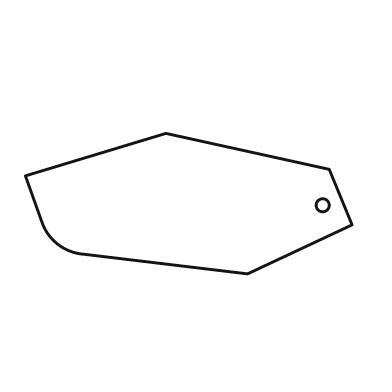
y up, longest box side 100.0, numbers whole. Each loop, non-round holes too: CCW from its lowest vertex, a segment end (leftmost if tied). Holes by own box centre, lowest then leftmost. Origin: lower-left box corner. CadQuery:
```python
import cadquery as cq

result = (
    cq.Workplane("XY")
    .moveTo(68.0, 0.0)
    .lineTo(100.0, 15.0)
    .lineTo(93.0, 32.0)
    .lineTo(43.0, 43.0)
    .lineTo(0.0, 30.0)
    .lineTo(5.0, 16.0)
    .threePointArc((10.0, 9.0), (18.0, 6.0))
    .close()
    .moveTo(91.0, 21.0)
    .circle(2.0)
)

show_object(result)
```